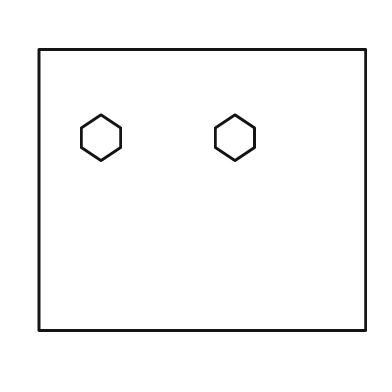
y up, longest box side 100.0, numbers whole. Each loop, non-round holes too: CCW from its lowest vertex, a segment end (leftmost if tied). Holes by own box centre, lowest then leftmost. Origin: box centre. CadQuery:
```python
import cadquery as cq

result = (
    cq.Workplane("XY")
    .moveTo(-50.0, -43.0)
    .lineTo(50.0, -43.0)
    .lineTo(50.0, 43.0)
    .lineTo(-50.0, 43.0)
    .close()
    .moveTo(-31.0, 9.0)
    .lineTo(-25.0, 13.0)
    .lineTo(-25.0, 19.0)
    .lineTo(-31.0, 23.0)
    .lineTo(-37.0, 19.0)
    .lineTo(-37.0, 13.0)
    .close()
    .moveTo(10.0, 9.0)
    .lineTo(16.0, 13.0)
    .lineTo(16.0, 19.0)
    .lineTo(10.0, 23.0)
    .lineTo(4.0, 19.0)
    .lineTo(4.0, 13.0)
    .close()
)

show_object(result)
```